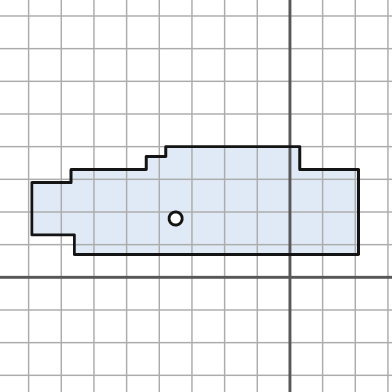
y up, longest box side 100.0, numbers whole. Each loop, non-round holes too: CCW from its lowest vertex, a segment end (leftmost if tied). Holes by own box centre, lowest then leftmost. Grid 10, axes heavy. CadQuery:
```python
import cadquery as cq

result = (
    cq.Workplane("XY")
    .moveTo(-66.0, 7.0)
    .lineTo(21.0, 7.0)
    .lineTo(21.0, 33.0)
    .lineTo(3.0, 33.0)
    .lineTo(3.0, 40.0)
    .lineTo(-38.0, 40.0)
    .lineTo(-38.0, 37.0)
    .lineTo(-44.0, 37.0)
    .lineTo(-44.0, 33.0)
    .lineTo(-67.0, 33.0)
    .lineTo(-67.0, 29.0)
    .lineTo(-79.0, 29.0)
    .lineTo(-79.0, 13.0)
    .lineTo(-66.0, 13.0)
    .close()
    .moveTo(-35.0, 18.0)
    .circle(2.0)
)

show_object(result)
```